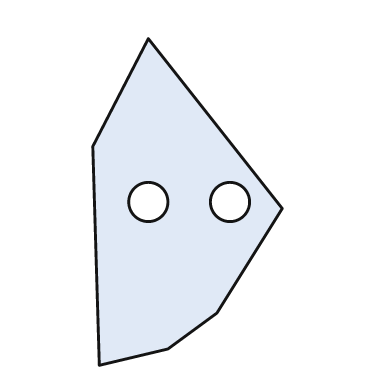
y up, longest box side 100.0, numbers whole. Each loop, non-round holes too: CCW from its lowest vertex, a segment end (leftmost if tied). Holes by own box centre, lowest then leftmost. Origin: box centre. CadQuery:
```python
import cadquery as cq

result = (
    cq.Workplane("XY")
    .moveTo(-27.0, -50.0)
    .lineTo(-6.0, -45.0)
    .lineTo(9.0, -34.0)
    .lineTo(29.0, -2.0)
    .lineTo(-12.0, 50.0)
    .lineTo(-29.0, 17.0)
    .close()
    .moveTo(-12.0, 0.0)
    .circle(6.0)
    .moveTo(13.0, 0.0)
    .circle(6.0)
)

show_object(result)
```